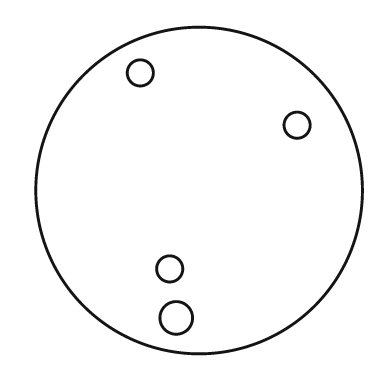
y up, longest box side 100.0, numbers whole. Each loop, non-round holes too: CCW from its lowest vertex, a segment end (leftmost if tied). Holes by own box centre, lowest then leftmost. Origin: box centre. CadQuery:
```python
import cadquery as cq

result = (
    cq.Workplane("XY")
    .moveTo(0.0, 0.0)
    .circle(50.0)
    .moveTo(-7.0, -39.0)
    .circle(5.0)
    .moveTo(-9.0, -24.0)
    .circle(4.0)
    .moveTo(30.0, 20.0)
    .circle(4.0)
    .moveTo(-18.0, 36.0)
    .circle(4.0)
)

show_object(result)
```